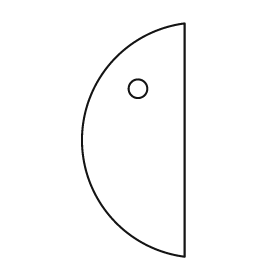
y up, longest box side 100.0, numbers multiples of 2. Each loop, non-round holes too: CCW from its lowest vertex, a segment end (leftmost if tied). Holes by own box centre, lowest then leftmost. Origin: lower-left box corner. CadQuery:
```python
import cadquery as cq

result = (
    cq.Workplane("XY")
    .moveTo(44.0, 0.0)
    .lineTo(44.0, 100.0)
    .threePointArc((0.0, 50.0), (44.0, 0.0))
    .close()
    .moveTo(24.0, 72.0)
    .circle(4.0)
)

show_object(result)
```